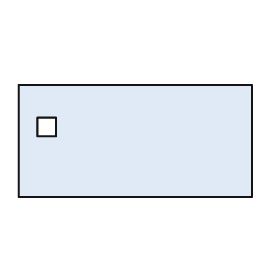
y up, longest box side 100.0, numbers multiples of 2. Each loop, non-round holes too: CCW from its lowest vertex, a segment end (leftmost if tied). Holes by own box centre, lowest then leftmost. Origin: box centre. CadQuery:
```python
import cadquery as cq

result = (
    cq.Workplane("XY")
    .moveTo(-50.0, -24.0)
    .lineTo(50.0, -24.0)
    .lineTo(50.0, 24.0)
    .lineTo(-50.0, 24.0)
    .close()
    .moveTo(-42.0, 2.0)
    .lineTo(-34.0, 2.0)
    .lineTo(-34.0, 10.0)
    .lineTo(-42.0, 10.0)
    .close()
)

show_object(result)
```